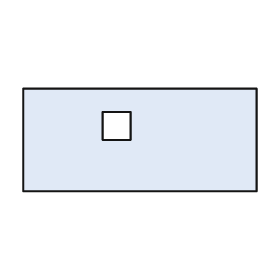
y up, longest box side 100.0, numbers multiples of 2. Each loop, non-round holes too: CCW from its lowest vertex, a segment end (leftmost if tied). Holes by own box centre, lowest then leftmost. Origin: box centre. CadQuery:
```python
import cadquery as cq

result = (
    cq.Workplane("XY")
    .moveTo(-50.0, -22.0)
    .lineTo(50.0, -22.0)
    .lineTo(50.0, 22.0)
    .lineTo(-50.0, 22.0)
    .close()
    .moveTo(-16.0, 0.0)
    .lineTo(-4.0, 0.0)
    .lineTo(-4.0, 12.0)
    .lineTo(-16.0, 12.0)
    .close()
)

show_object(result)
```